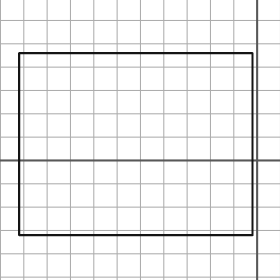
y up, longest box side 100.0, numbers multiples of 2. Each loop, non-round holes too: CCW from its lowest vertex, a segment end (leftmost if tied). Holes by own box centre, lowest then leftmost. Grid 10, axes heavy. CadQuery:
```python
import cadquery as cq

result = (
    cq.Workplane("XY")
    .moveTo(-102.0, -32.0)
    .lineTo(-2.0, -32.0)
    .lineTo(-2.0, 46.0)
    .lineTo(-102.0, 46.0)
    .close()
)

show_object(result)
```